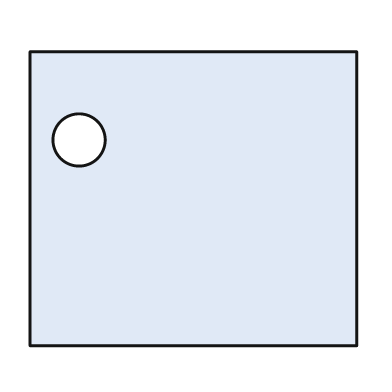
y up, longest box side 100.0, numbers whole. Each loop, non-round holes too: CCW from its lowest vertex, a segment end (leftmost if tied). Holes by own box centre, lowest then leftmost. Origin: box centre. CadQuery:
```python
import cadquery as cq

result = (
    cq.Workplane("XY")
    .moveTo(-50.0, -45.0)
    .lineTo(50.0, -45.0)
    .lineTo(50.0, 45.0)
    .lineTo(-50.0, 45.0)
    .close()
    .moveTo(-35.0, 18.0)
    .circle(8.0)
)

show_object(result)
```